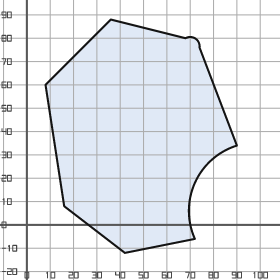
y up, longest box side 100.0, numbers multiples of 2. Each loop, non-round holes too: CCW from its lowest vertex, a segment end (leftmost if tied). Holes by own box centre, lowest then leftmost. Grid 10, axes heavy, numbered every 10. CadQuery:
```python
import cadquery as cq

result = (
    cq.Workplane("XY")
    .moveTo(42.0, -12.0)
    .lineTo(72.0, -6.0)
    .threePointArc((72.0, 18.0), (90.0, 34.0))
    .lineTo(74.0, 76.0)
    .threePointArc((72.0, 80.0), (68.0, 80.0))
    .lineTo(36.0, 88.0)
    .lineTo(8.0, 60.0)
    .lineTo(16.0, 8.0)
    .close()
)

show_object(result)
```